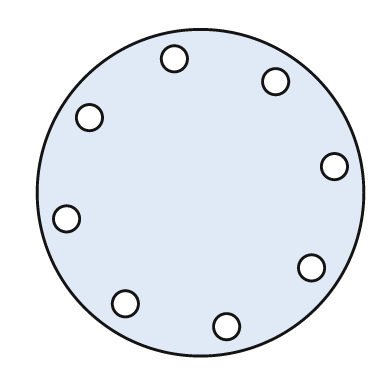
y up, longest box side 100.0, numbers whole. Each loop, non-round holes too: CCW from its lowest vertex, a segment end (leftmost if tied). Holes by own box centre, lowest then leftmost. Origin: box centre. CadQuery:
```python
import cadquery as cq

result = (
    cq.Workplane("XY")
    .moveTo(0.0, 0.0)
    .circle(50.0)
    .moveTo(8.0, -41.0)
    .circle(4.0)
    .moveTo(-23.0, -34.0)
    .circle(4.0)
    .moveTo(34.0, -23.0)
    .circle(4.0)
    .moveTo(-41.0, -8.0)
    .circle(4.0)
    .moveTo(41.0, 8.0)
    .circle(4.0)
    .moveTo(-34.0, 23.0)
    .circle(4.0)
    .moveTo(23.0, 34.0)
    .circle(4.0)
    .moveTo(-8.0, 41.0)
    .circle(4.0)
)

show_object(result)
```